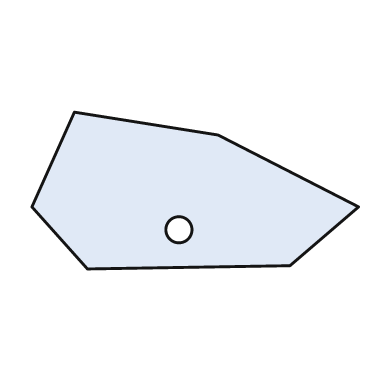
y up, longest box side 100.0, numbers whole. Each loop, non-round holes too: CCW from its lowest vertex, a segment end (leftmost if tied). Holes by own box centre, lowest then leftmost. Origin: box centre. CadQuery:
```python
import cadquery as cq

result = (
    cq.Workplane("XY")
    .moveTo(-33.0, -24.0)
    .lineTo(29.0, -23.0)
    .lineTo(50.0, -5.0)
    .lineTo(7.0, 17.0)
    .lineTo(-37.0, 24.0)
    .lineTo(-50.0, -5.0)
    .close()
    .moveTo(-5.0, -12.0)
    .circle(4.0)
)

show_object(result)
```